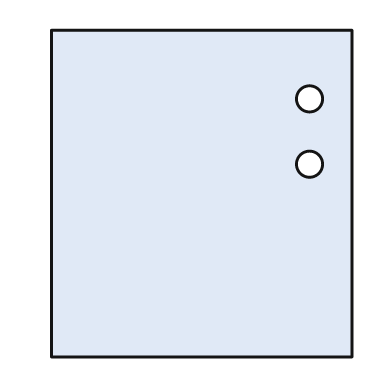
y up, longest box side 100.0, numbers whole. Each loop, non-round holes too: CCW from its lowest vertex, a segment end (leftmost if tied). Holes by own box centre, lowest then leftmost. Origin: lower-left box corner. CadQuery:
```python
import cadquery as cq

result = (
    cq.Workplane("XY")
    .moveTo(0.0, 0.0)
    .lineTo(92.0, 0.0)
    .lineTo(92.0, 100.0)
    .lineTo(0.0, 100.0)
    .close()
    .moveTo(79.0, 59.0)
    .circle(4.0)
    .moveTo(79.0, 79.0)
    .circle(4.0)
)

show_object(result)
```